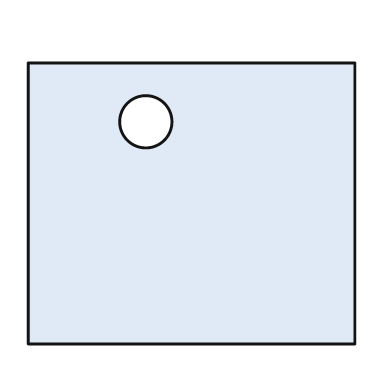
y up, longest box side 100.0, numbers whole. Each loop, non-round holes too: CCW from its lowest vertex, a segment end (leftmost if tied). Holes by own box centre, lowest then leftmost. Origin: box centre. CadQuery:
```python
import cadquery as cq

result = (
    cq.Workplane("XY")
    .moveTo(-50.0, -43.0)
    .lineTo(50.0, -43.0)
    .lineTo(50.0, 43.0)
    .lineTo(-50.0, 43.0)
    .close()
    .moveTo(-14.0, 25.0)
    .circle(8.0)
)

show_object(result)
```